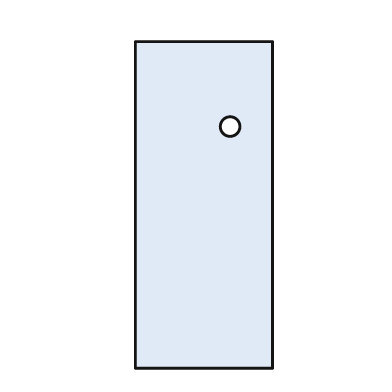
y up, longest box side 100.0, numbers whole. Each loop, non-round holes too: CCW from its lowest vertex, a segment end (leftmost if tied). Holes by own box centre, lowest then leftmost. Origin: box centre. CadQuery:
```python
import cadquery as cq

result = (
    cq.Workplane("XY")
    .moveTo(-21.0, -50.0)
    .lineTo(21.0, -50.0)
    .lineTo(21.0, 50.0)
    .lineTo(-21.0, 50.0)
    .close()
    .moveTo(8.0, 24.0)
    .circle(3.0)
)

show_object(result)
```